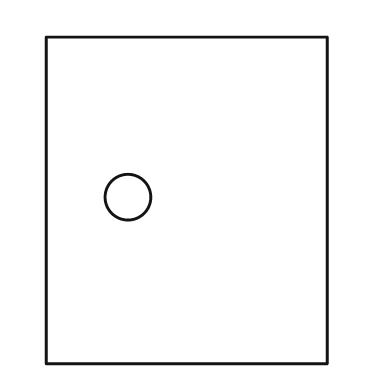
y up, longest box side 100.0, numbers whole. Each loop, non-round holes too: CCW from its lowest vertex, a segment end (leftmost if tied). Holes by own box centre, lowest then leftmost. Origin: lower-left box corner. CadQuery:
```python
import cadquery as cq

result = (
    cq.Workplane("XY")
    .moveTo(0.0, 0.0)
    .lineTo(86.0, 0.0)
    .lineTo(86.0, 100.0)
    .lineTo(0.0, 100.0)
    .close()
    .moveTo(25.0, 51.0)
    .circle(7.0)
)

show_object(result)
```